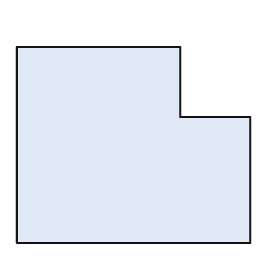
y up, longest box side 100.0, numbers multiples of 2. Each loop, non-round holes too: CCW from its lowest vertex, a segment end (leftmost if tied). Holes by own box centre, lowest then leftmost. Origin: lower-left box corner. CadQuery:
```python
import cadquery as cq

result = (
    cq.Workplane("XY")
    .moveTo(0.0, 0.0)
    .lineTo(100.0, 0.0)
    .lineTo(100.0, 54.0)
    .lineTo(70.0, 54.0)
    .lineTo(70.0, 84.0)
    .lineTo(0.0, 84.0)
    .close()
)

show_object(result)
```